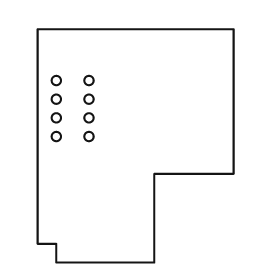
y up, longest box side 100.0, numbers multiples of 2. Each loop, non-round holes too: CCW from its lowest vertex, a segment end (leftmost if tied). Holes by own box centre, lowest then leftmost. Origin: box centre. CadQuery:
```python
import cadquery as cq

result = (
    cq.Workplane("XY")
    .moveTo(-34.0, -50.0)
    .lineTo(8.0, -50.0)
    .lineTo(8.0, -12.0)
    .lineTo(42.0, -12.0)
    .lineTo(42.0, 50.0)
    .lineTo(-42.0, 50.0)
    .lineTo(-42.0, -42.0)
    .lineTo(-34.0, -42.0)
    .close()
    .moveTo(-34.0, 4.0)
    .circle(2.0)
    .moveTo(-20.0, 4.0)
    .circle(2.0)
    .moveTo(-34.0, 12.0)
    .circle(2.0)
    .moveTo(-20.0, 12.0)
    .circle(2.0)
    .moveTo(-34.0, 20.0)
    .circle(2.0)
    .moveTo(-20.0, 20.0)
    .circle(2.0)
    .moveTo(-34.0, 28.0)
    .circle(2.0)
    .moveTo(-20.0, 28.0)
    .circle(2.0)
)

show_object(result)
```